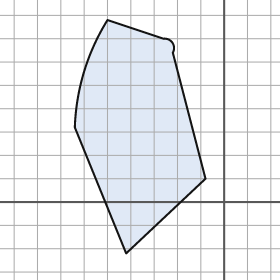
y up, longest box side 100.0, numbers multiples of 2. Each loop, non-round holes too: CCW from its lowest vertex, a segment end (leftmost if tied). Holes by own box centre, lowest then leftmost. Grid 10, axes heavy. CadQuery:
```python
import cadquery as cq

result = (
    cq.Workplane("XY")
    .moveTo(-42.0, -22.0)
    .lineTo(-8.0, 10.0)
    .lineTo(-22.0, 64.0)
    .threePointArc((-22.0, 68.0), (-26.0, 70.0))
    .lineTo(-50.0, 78.0)
    .threePointArc((-60.0, 56.0), (-64.0, 32.0))
    .close()
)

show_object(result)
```